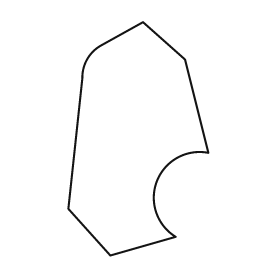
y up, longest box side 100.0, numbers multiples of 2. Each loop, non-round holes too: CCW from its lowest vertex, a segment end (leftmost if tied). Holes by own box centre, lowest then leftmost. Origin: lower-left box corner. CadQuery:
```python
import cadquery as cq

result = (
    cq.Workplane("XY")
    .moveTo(18.0, 0.0)
    .lineTo(46.0, 8.0)
    .threePointArc((38.0, 32.0), (60.0, 44.0))
    .lineTo(50.0, 84.0)
    .lineTo(32.0, 100.0)
    .lineTo(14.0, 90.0)
    .threePointArc((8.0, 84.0), (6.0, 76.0))
    .lineTo(0.0, 20.0)
    .close()
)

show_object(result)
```